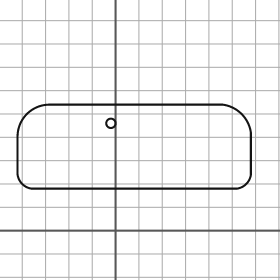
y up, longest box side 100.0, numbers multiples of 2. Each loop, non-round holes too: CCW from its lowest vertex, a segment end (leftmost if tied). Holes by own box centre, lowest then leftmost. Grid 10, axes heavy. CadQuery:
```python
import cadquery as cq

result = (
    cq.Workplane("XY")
    .moveTo(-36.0, 18.0)
    .lineTo(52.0, 18.0)
    .threePointArc((56.0, 20.0), (58.0, 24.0))
    .lineTo(58.0, 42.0)
    .threePointArc((54.0, 50.0), (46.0, 54.0))
    .lineTo(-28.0, 54.0)
    .threePointArc((-38.0, 50.0), (-42.0, 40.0))
    .lineTo(-42.0, 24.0)
    .threePointArc((-40.0, 20.0), (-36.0, 18.0))
    .close()
    .moveTo(-2.0, 46.0)
    .circle(2.0)
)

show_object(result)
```